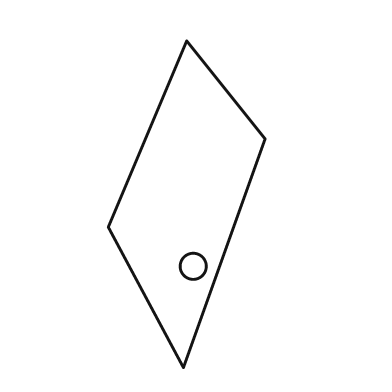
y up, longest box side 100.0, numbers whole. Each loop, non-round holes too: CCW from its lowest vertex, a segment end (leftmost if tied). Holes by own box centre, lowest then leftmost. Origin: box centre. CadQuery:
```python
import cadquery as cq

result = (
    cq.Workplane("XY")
    .moveTo(-1.0, -50.0)
    .lineTo(24.0, 20.0)
    .lineTo(0.0, 50.0)
    .lineTo(-24.0, -7.0)
    .close()
    .moveTo(2.0, -19.0)
    .circle(4.0)
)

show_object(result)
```